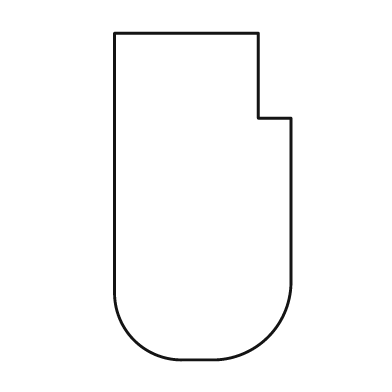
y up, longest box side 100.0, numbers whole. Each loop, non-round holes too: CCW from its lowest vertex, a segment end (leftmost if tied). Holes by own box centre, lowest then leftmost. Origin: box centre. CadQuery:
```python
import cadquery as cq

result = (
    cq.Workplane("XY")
    .moveTo(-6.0, -50.0)
    .lineTo(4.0, -50.0)
    .threePointArc((20.0, -43.0), (27.0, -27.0))
    .lineTo(27.0, 24.0)
    .lineTo(17.0, 24.0)
    .lineTo(17.0, 50.0)
    .lineTo(-27.0, 50.0)
    .lineTo(-27.0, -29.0)
    .threePointArc((-21.0, -44.0), (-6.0, -50.0))
    .close()
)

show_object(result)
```